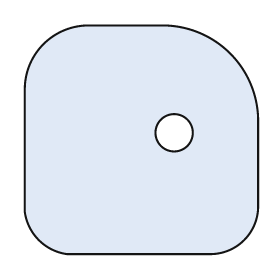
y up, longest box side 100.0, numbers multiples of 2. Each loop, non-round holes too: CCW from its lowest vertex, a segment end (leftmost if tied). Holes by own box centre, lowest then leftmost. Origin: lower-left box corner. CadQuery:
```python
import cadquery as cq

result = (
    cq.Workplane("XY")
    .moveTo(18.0, 0.0)
    .lineTo(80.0, 0.0)
    .threePointArc((94.0, 6.0), (100.0, 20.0))
    .lineTo(100.0, 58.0)
    .threePointArc((88.0, 86.0), (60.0, 98.0))
    .lineTo(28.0, 98.0)
    .threePointArc((8.0, 90.0), (0.0, 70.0))
    .lineTo(0.0, 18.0)
    .threePointArc((6.0, 6.0), (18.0, 0.0))
    .close()
    .moveTo(64.0, 52.0)
    .circle(8.0)
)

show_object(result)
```